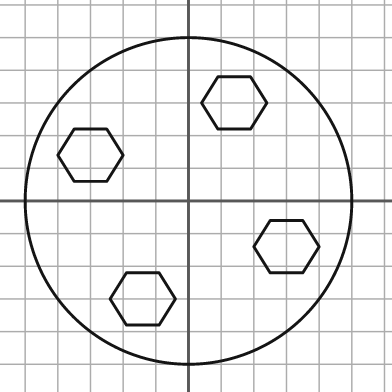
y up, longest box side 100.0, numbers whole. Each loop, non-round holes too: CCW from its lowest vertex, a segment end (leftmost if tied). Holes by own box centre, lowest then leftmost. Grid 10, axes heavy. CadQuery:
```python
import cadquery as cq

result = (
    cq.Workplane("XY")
    .moveTo(0.0, 0.0)
    .circle(50.0)
    .moveTo(-19.0, -38.0)
    .lineTo(-9.0, -38.0)
    .lineTo(-4.0, -30.0)
    .lineTo(-9.0, -22.0)
    .lineTo(-19.0, -22.0)
    .lineTo(-24.0, -30.0)
    .close()
    .moveTo(25.0, -22.0)
    .lineTo(35.0, -22.0)
    .lineTo(40.0, -14.0)
    .lineTo(35.0, -6.0)
    .lineTo(25.0, -6.0)
    .lineTo(20.0, -14.0)
    .close()
    .moveTo(-35.0, 6.0)
    .lineTo(-25.0, 6.0)
    .lineTo(-20.0, 14.0)
    .lineTo(-25.0, 22.0)
    .lineTo(-35.0, 22.0)
    .lineTo(-40.0, 14.0)
    .close()
    .moveTo(9.0, 22.0)
    .lineTo(19.0, 22.0)
    .lineTo(24.0, 30.0)
    .lineTo(19.0, 38.0)
    .lineTo(9.0, 38.0)
    .lineTo(4.0, 30.0)
    .close()
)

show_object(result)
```